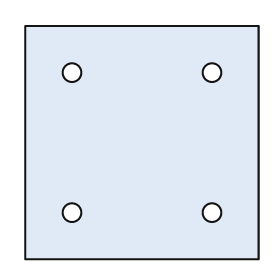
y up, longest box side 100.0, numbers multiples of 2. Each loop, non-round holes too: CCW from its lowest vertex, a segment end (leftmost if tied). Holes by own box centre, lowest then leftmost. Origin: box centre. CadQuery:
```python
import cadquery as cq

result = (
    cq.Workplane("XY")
    .moveTo(-50.0, -50.0)
    .lineTo(50.0, -50.0)
    .lineTo(50.0, 50.0)
    .lineTo(-50.0, 50.0)
    .close()
    .moveTo(-30.0, -30.0)
    .circle(4.0)
    .moveTo(30.0, -30.0)
    .circle(4.0)
    .moveTo(-30.0, 30.0)
    .circle(4.0)
    .moveTo(30.0, 30.0)
    .circle(4.0)
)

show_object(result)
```